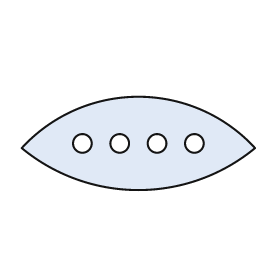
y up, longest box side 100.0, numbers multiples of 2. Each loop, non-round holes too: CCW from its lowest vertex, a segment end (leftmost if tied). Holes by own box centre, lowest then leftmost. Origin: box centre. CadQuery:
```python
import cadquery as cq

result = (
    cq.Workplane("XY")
    .moveTo(-50.0, -2.0)
    .threePointArc((0.0, -20.0), (50.0, -2.0))
    .threePointArc((0.0, 20.0), (-50.0, -2.0))
    .close()
    .moveTo(-24.0, 0.0)
    .circle(4.0)
    .moveTo(-8.0, 0.0)
    .circle(4.0)
    .moveTo(8.0, 0.0)
    .circle(4.0)
    .moveTo(24.0, 0.0)
    .circle(4.0)
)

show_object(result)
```